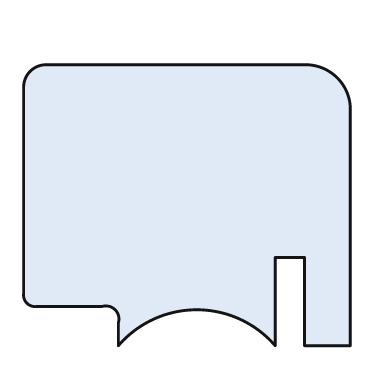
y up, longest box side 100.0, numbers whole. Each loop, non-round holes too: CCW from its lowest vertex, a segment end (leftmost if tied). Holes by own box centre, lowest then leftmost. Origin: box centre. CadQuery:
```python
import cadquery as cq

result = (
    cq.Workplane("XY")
    .moveTo(-21.0, -43.0)
    .threePointArc((3.0, -32.0), (27.0, -43.0))
    .lineTo(27.0, -16.0)
    .lineTo(36.0, -16.0)
    .lineTo(36.0, -43.0)
    .lineTo(50.0, -43.0)
    .lineTo(50.0, 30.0)
    .threePointArc((46.0, 39.0), (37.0, 43.0))
    .lineTo(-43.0, 43.0)
    .threePointArc((-48.0, 41.0), (-50.0, 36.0))
    .lineTo(-50.0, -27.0)
    .threePointArc((-49.0, -30.0), (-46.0, -31.0))
    .lineTo(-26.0, -31.0)
    .threePointArc((-22.0, -32.0), (-21.0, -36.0))
    .close()
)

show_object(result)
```